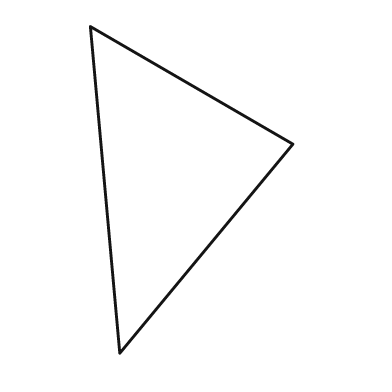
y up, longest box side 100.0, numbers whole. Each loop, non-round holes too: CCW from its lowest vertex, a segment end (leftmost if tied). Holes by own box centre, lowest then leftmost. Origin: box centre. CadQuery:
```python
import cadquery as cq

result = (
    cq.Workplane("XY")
    .moveTo(-22.0, -50.0)
    .lineTo(31.0, 14.0)
    .lineTo(-31.0, 50.0)
    .close()
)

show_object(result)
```